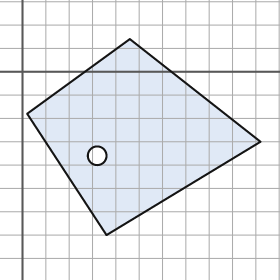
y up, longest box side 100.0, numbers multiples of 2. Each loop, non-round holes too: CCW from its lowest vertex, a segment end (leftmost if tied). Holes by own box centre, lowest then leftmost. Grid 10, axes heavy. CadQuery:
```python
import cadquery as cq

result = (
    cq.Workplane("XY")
    .moveTo(36.0, -70.0)
    .lineTo(102.0, -30.0)
    .lineTo(46.0, 14.0)
    .lineTo(2.0, -18.0)
    .close()
    .moveTo(32.0, -36.0)
    .circle(4.0)
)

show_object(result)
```